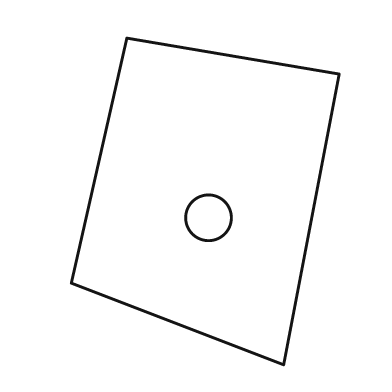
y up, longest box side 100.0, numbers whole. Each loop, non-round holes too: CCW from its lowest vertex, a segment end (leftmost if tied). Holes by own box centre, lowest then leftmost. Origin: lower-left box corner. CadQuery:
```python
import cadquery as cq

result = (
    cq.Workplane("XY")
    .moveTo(65.0, 0.0)
    .lineTo(82.0, 89.0)
    .lineTo(17.0, 100.0)
    .lineTo(0.0, 25.0)
    .close()
    .moveTo(42.0, 45.0)
    .circle(7.0)
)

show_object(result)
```